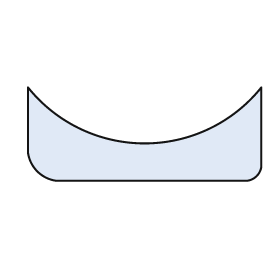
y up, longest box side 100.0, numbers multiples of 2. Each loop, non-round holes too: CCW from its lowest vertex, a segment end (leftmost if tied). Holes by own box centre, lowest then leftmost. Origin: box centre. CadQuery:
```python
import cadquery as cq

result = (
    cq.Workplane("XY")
    .moveTo(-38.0, -20.0)
    .lineTo(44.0, -20.0)
    .threePointArc((48.0, -18.0), (50.0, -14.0))
    .lineTo(50.0, 20.0)
    .threePointArc((0.0, -4.0), (-50.0, 20.0))
    .lineTo(-50.0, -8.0)
    .threePointArc((-46.0, -16.0), (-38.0, -20.0))
    .close()
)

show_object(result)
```